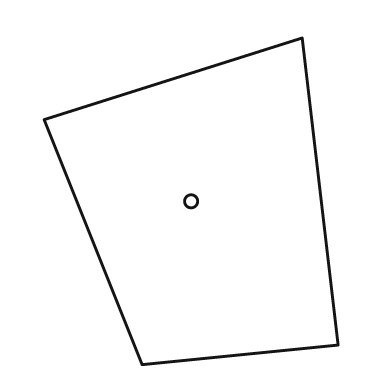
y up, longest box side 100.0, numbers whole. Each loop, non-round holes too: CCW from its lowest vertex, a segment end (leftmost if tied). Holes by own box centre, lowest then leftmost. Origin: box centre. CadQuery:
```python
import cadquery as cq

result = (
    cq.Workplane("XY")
    .moveTo(-15.0, -50.0)
    .lineTo(45.0, -44.0)
    .lineTo(34.0, 50.0)
    .lineTo(-45.0, 25.0)
    .close()
    .moveTo(0.0, 0.0)
    .circle(2.0)
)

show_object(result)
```